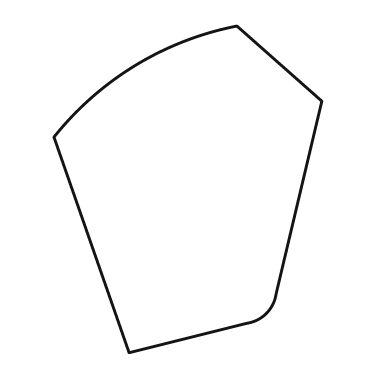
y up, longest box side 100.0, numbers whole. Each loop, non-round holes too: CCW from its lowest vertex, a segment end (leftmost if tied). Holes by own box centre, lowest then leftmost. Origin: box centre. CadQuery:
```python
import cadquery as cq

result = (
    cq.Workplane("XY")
    .moveTo(-18.0, -50.0)
    .lineTo(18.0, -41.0)
    .threePointArc((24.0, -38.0), (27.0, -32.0))
    .lineTo(41.0, 27.0)
    .lineTo(15.0, 50.0)
    .threePointArc((-16.0, 38.0), (-41.0, 16.0))
    .close()
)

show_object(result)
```